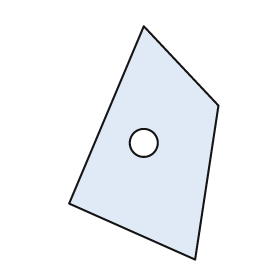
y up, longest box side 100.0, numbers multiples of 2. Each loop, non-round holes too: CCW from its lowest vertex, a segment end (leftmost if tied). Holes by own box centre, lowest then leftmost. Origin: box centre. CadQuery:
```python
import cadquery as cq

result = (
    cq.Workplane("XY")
    .moveTo(22.0, -50.0)
    .lineTo(32.0, 16.0)
    .lineTo(0.0, 50.0)
    .lineTo(-32.0, -26.0)
    .close()
    .moveTo(0.0, 0.0)
    .circle(6.0)
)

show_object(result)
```